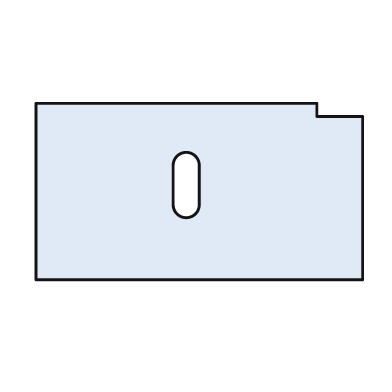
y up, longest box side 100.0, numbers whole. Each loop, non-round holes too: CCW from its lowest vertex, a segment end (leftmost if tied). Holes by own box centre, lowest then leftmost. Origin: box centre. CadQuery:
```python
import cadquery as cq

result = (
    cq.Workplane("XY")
    .moveTo(-50.0, -27.0)
    .lineTo(50.0, -27.0)
    .lineTo(50.0, 23.0)
    .lineTo(36.0, 23.0)
    .lineTo(36.0, 27.0)
    .lineTo(-50.0, 27.0)
    .close()
    .moveTo(-8.0, -4.0)
    .threePointArc((-4.0, -8.0), (0.0, -4.0))
    .lineTo(0.0, 8.0)
    .threePointArc((-4.0, 12.0), (-8.0, 8.0))
    .close()
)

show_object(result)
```